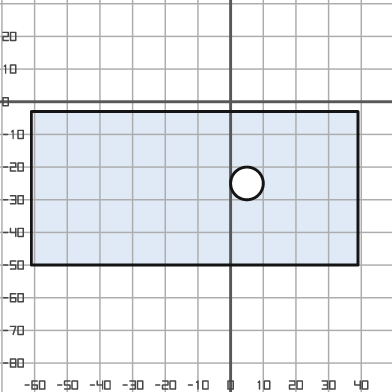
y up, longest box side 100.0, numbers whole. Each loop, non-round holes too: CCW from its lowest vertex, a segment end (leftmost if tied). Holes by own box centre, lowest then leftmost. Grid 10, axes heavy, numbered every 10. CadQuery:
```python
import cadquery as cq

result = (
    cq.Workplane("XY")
    .moveTo(-61.0, -50.0)
    .lineTo(39.0, -50.0)
    .lineTo(39.0, -3.0)
    .lineTo(-61.0, -3.0)
    .close()
    .moveTo(5.0, -25.0)
    .circle(5.0)
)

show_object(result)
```